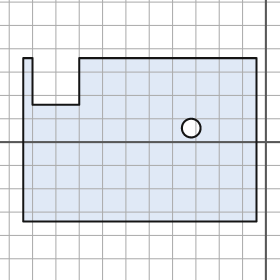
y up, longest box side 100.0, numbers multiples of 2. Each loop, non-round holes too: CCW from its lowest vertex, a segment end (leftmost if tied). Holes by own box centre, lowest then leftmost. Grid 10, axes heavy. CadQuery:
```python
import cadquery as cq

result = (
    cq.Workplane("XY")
    .moveTo(-104.0, -34.0)
    .lineTo(-4.0, -34.0)
    .lineTo(-4.0, 36.0)
    .lineTo(-80.0, 36.0)
    .lineTo(-80.0, 16.0)
    .lineTo(-100.0, 16.0)
    .lineTo(-100.0, 36.0)
    .lineTo(-104.0, 36.0)
    .close()
    .moveTo(-32.0, 6.0)
    .circle(4.0)
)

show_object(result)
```